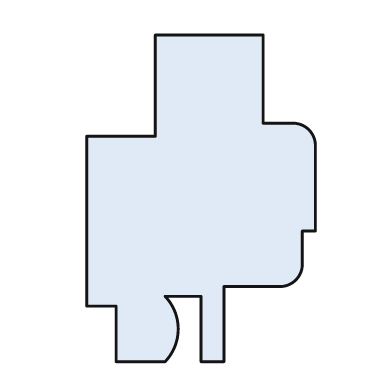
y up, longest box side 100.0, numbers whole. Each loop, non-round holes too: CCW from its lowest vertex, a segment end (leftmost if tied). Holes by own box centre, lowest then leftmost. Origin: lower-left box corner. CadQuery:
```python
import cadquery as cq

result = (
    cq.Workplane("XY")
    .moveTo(9.0, 0.0)
    .lineTo(24.0, 0.0)
    .threePointArc((28.0, 10.0), (24.0, 20.0))
    .lineTo(35.0, 20.0)
    .lineTo(35.0, 0.0)
    .lineTo(42.0, 0.0)
    .lineTo(42.0, 23.0)
    .lineTo(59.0, 23.0)
    .threePointArc((64.0, 25.0), (66.0, 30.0))
    .lineTo(66.0, 40.0)
    .lineTo(70.0, 40.0)
    .lineTo(70.0, 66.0)
    .threePointArc((68.0, 71.0), (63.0, 73.0))
    .lineTo(54.0, 73.0)
    .lineTo(54.0, 100.0)
    .lineTo(21.0, 100.0)
    .lineTo(21.0, 69.0)
    .lineTo(0.0, 69.0)
    .lineTo(0.0, 17.0)
    .lineTo(9.0, 17.0)
    .close()
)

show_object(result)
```